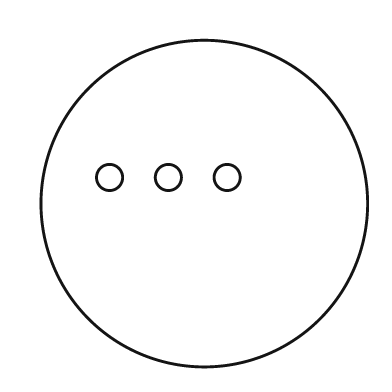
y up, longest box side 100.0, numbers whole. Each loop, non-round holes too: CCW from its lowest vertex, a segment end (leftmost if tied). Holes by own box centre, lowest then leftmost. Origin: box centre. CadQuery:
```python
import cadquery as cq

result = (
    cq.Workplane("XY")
    .moveTo(0.0, 0.0)
    .circle(50.0)
    .moveTo(-29.0, 8.0)
    .circle(4.0)
    .moveTo(-11.0, 8.0)
    .circle(4.0)
    .moveTo(7.0, 8.0)
    .circle(4.0)
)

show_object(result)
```